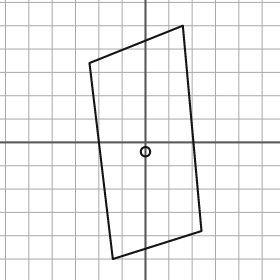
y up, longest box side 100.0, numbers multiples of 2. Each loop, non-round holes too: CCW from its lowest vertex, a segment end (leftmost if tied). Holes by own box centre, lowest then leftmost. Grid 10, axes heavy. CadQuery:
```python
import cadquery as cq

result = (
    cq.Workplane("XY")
    .moveTo(-14.0, -50.0)
    .lineTo(24.0, -38.0)
    .lineTo(16.0, 50.0)
    .lineTo(-24.0, 34.0)
    .close()
    .moveTo(0.0, -4.0)
    .circle(2.0)
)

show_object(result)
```